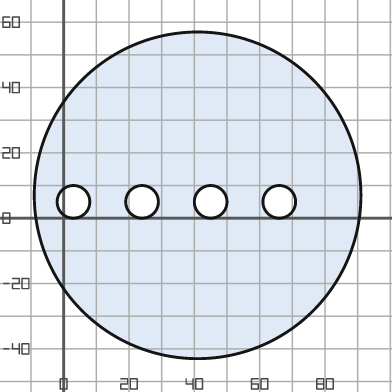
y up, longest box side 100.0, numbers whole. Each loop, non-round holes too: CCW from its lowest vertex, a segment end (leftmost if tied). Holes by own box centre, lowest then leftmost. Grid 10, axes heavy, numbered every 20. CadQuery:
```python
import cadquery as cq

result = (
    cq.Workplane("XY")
    .moveTo(41.0, 7.0)
    .circle(50.0)
    .moveTo(3.0, 5.0)
    .circle(5.0)
    .moveTo(24.0, 5.0)
    .circle(5.0)
    .moveTo(45.0, 5.0)
    .circle(5.0)
    .moveTo(66.0, 5.0)
    .circle(5.0)
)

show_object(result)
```